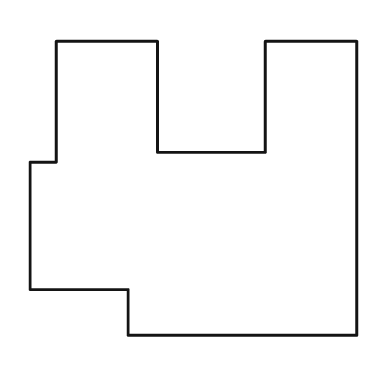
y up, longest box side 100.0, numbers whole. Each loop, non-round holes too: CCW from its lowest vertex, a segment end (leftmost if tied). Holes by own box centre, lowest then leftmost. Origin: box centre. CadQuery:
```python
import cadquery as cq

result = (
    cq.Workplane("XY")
    .moveTo(-20.0, -45.0)
    .lineTo(50.0, -45.0)
    .lineTo(50.0, 45.0)
    .lineTo(22.0, 45.0)
    .lineTo(22.0, 11.0)
    .lineTo(-11.0, 11.0)
    .lineTo(-11.0, 45.0)
    .lineTo(-42.0, 45.0)
    .lineTo(-42.0, 8.0)
    .lineTo(-50.0, 8.0)
    .lineTo(-50.0, -31.0)
    .lineTo(-20.0, -31.0)
    .close()
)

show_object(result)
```